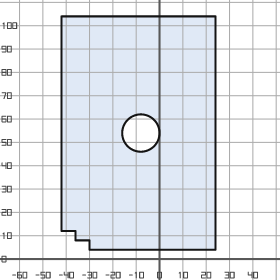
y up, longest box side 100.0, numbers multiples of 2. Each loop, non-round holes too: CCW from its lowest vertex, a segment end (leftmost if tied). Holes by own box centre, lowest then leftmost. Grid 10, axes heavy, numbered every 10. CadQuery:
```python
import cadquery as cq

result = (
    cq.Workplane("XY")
    .moveTo(-30.0, 4.0)
    .lineTo(24.0, 4.0)
    .lineTo(24.0, 104.0)
    .lineTo(-42.0, 104.0)
    .lineTo(-42.0, 12.0)
    .lineTo(-36.0, 12.0)
    .lineTo(-36.0, 8.0)
    .lineTo(-30.0, 8.0)
    .close()
    .moveTo(-8.0, 54.0)
    .circle(8.0)
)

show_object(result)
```